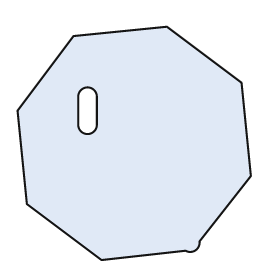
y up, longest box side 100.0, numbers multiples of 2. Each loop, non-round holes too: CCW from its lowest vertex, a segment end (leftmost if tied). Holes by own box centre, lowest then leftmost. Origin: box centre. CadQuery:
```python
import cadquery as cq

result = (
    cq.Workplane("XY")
    .moveTo(-14.0, -50.0)
    .lineTo(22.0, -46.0)
    .threePointArc((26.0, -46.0), (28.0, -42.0))
    .lineTo(50.0, -14.0)
    .lineTo(46.0, 26.0)
    .lineTo(14.0, 50.0)
    .lineTo(-26.0, 46.0)
    .lineTo(-50.0, 14.0)
    .lineTo(-46.0, -26.0)
    .close()
    .moveTo(-24.0, 8.0)
    .threePointArc((-20.0, 4.0), (-16.0, 8.0))
    .lineTo(-16.0, 20.0)
    .threePointArc((-20.0, 24.0), (-24.0, 20.0))
    .close()
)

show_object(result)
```